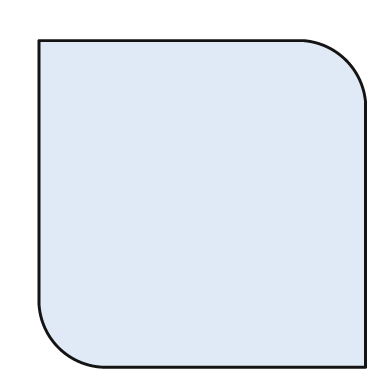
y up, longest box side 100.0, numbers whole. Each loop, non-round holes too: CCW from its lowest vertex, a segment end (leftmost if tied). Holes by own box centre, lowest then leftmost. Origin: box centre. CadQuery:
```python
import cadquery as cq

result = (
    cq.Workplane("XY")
    .moveTo(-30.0, -50.0)
    .lineTo(50.0, -50.0)
    .lineTo(50.0, 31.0)
    .threePointArc((44.0, 44.0), (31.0, 50.0))
    .lineTo(-50.0, 50.0)
    .lineTo(-50.0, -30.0)
    .threePointArc((-44.0, -44.0), (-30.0, -50.0))
    .close()
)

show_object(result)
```